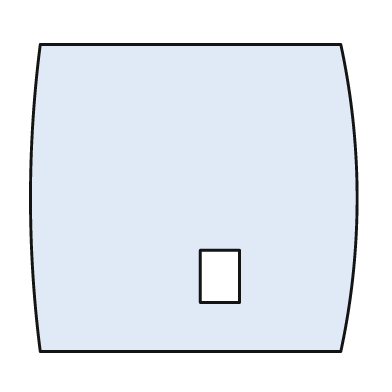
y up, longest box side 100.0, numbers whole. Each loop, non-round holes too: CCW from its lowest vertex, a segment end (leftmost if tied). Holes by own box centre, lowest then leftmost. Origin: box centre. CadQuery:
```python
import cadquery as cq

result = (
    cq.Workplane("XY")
    .moveTo(-47.0, -47.0)
    .lineTo(45.0, -47.0)
    .threePointArc((50.0, 0.0), (45.0, 47.0))
    .lineTo(-47.0, 47.0)
    .threePointArc((-50.0, 0.0), (-47.0, -47.0))
    .close()
    .moveTo(2.0, -32.0)
    .lineTo(14.0, -32.0)
    .lineTo(14.0, -16.0)
    .lineTo(2.0, -16.0)
    .close()
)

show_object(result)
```